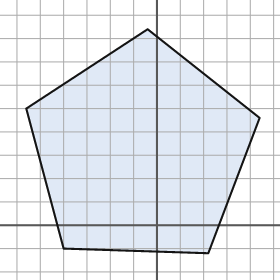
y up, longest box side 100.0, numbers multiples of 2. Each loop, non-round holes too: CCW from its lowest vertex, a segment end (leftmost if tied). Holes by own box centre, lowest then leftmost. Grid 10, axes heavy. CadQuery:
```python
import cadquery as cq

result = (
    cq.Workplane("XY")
    .moveTo(22.0, -12.0)
    .lineTo(44.0, 46.0)
    .lineTo(-4.0, 84.0)
    .lineTo(-56.0, 50.0)
    .lineTo(-40.0, -10.0)
    .close()
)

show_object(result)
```